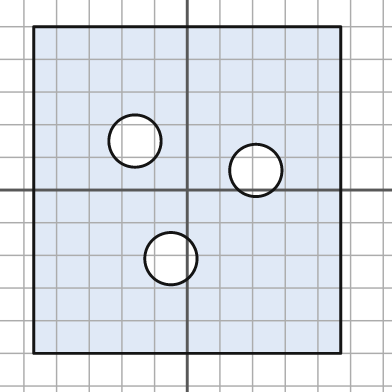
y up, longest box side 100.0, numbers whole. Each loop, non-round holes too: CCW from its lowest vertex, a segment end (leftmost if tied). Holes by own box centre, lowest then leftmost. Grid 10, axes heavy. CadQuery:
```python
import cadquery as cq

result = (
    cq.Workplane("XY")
    .moveTo(-47.0, -50.0)
    .lineTo(47.0, -50.0)
    .lineTo(47.0, 50.0)
    .lineTo(-47.0, 50.0)
    .close()
    .moveTo(-5.0, -21.0)
    .circle(8.0)
    .moveTo(21.0, 6.0)
    .circle(8.0)
    .moveTo(-16.0, 15.0)
    .circle(8.0)
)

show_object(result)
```